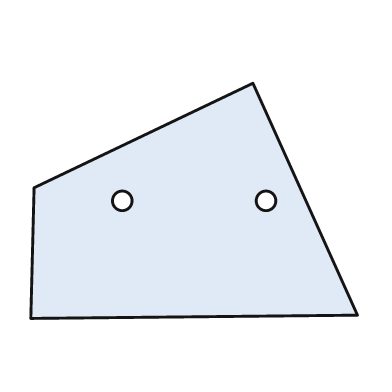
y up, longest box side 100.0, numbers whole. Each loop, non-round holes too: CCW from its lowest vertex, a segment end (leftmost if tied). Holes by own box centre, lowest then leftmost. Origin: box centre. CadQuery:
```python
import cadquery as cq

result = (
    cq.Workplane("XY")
    .moveTo(-50.0, -36.0)
    .lineTo(50.0, -35.0)
    .lineTo(18.0, 36.0)
    .lineTo(-49.0, 4.0)
    .close()
    .moveTo(-22.0, 0.0)
    .circle(3.0)
    .moveTo(22.0, 0.0)
    .circle(3.0)
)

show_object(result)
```